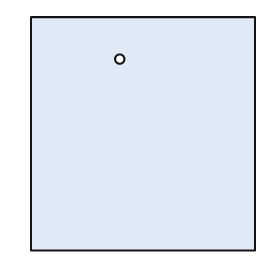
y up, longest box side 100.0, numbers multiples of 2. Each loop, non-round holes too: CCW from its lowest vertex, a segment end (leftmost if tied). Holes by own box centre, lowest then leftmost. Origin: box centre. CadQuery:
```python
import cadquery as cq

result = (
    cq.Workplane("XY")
    .moveTo(-48.0, -50.0)
    .lineTo(48.0, -50.0)
    .lineTo(48.0, 50.0)
    .lineTo(-48.0, 50.0)
    .close()
    .moveTo(-10.0, 32.0)
    .circle(2.0)
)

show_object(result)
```